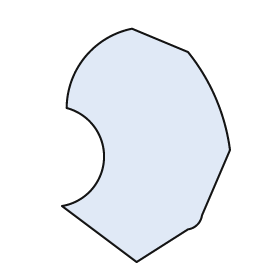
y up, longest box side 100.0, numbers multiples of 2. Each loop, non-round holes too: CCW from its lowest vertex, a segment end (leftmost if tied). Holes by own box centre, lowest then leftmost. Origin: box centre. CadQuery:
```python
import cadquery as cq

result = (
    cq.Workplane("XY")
    .moveTo(-4.0, -50.0)
    .lineTo(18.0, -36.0)
    .threePointArc((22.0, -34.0), (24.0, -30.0))
    .lineTo(36.0, -2.0)
    .threePointArc((30.0, 20.0), (18.0, 40.0))
    .lineTo(-6.0, 50.0)
    .threePointArc((-26.0, 38.0), (-34.0, 16.0))
    .threePointArc((-18.0, -6.0), (-36.0, -26.0))
    .close()
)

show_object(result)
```